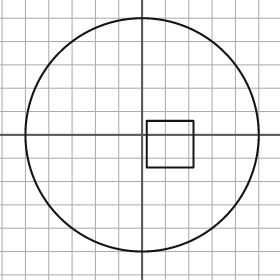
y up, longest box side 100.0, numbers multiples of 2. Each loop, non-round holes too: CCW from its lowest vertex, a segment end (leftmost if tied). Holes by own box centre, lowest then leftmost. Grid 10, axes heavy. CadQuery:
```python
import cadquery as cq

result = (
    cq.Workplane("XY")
    .moveTo(0.0, 0.0)
    .circle(50.0)
    .moveTo(2.0, -14.0)
    .lineTo(22.0, -14.0)
    .lineTo(22.0, 6.0)
    .lineTo(2.0, 6.0)
    .close()
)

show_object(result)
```